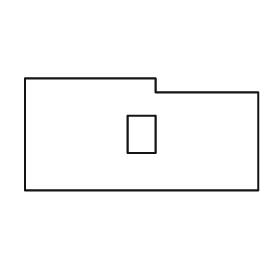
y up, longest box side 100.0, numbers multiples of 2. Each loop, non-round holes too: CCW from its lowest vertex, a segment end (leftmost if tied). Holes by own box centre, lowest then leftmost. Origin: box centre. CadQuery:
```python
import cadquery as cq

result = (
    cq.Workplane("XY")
    .moveTo(-50.0, -24.0)
    .lineTo(50.0, -24.0)
    .lineTo(50.0, 18.0)
    .lineTo(6.0, 18.0)
    .lineTo(6.0, 24.0)
    .lineTo(-50.0, 24.0)
    .close()
    .moveTo(-6.0, -8.0)
    .lineTo(6.0, -8.0)
    .lineTo(6.0, 8.0)
    .lineTo(-6.0, 8.0)
    .close()
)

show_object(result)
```